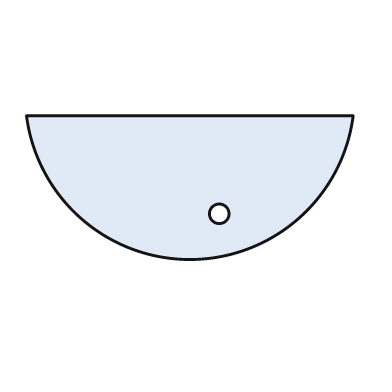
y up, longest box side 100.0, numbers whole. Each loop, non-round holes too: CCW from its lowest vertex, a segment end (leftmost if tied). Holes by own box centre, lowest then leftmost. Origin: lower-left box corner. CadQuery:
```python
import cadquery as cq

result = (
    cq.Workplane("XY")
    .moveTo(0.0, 44.0)
    .threePointArc((50.0, 0.0), (100.0, 44.0))
    .close()
    .moveTo(59.0, 14.0)
    .circle(3.0)
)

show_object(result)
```